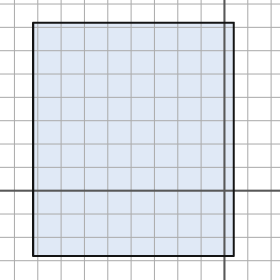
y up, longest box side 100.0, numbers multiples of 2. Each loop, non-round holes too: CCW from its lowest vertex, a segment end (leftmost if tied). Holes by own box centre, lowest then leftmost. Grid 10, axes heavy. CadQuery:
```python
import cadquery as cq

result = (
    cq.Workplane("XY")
    .moveTo(-82.0, -28.0)
    .lineTo(4.0, -28.0)
    .lineTo(4.0, 72.0)
    .lineTo(-82.0, 72.0)
    .close()
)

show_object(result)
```